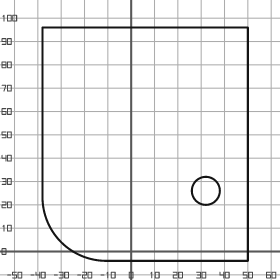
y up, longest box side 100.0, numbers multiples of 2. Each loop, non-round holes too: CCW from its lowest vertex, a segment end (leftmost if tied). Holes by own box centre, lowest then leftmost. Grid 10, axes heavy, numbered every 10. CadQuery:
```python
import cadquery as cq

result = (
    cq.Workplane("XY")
    .moveTo(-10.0, -4.0)
    .lineTo(50.0, -4.0)
    .lineTo(50.0, 96.0)
    .lineTo(-38.0, 96.0)
    .lineTo(-38.0, 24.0)
    .threePointArc((-30.0, 4.0), (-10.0, -4.0))
    .close()
    .moveTo(32.0, 26.0)
    .circle(6.0)
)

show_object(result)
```